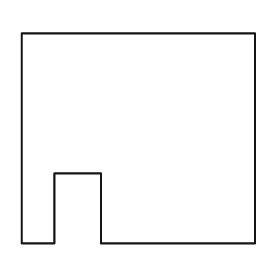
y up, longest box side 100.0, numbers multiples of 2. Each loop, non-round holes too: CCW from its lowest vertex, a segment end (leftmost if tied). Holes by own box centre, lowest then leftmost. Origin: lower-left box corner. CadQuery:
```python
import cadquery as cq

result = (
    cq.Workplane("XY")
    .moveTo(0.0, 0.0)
    .lineTo(14.0, 0.0)
    .lineTo(14.0, 30.0)
    .lineTo(34.0, 30.0)
    .lineTo(34.0, 0.0)
    .lineTo(100.0, 0.0)
    .lineTo(100.0, 90.0)
    .lineTo(0.0, 90.0)
    .close()
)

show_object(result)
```